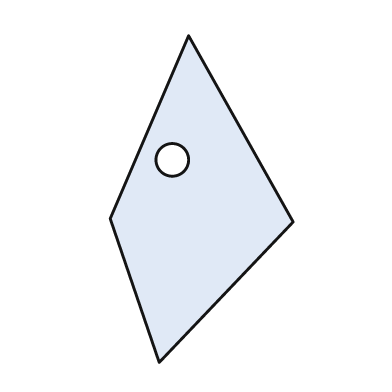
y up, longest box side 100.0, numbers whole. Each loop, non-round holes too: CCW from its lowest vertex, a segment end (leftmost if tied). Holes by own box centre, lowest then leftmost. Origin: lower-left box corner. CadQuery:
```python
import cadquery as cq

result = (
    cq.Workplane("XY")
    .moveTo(15.0, 0.0)
    .lineTo(56.0, 43.0)
    .lineTo(24.0, 100.0)
    .lineTo(0.0, 44.0)
    .close()
    .moveTo(19.0, 62.0)
    .circle(5.0)
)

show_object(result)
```